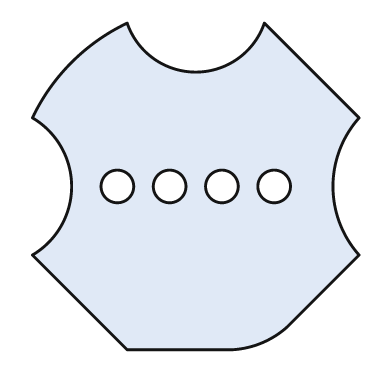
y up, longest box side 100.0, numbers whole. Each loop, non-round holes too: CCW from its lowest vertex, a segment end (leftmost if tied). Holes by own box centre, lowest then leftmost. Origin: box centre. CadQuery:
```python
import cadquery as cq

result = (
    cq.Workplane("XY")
    .moveTo(-21.0, -50.0)
    .lineTo(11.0, -50.0)
    .threePointArc((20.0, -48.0), (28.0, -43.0))
    .lineTo(50.0, -21.0)
    .threePointArc((42.0, 0.0), (50.0, 21.0))
    .lineTo(21.0, 50.0)
    .threePointArc((0.0, 35.0), (-21.0, 50.0))
    .threePointArc((-38.0, 38.0), (-50.0, 21.0))
    .threePointArc((-38.0, 0.0), (-50.0, -21.0))
    .close()
    .moveTo(-24.0, 0.0)
    .circle(5.0)
    .moveTo(-8.0, 0.0)
    .circle(5.0)
    .moveTo(8.0, 0.0)
    .circle(5.0)
    .moveTo(24.0, 0.0)
    .circle(5.0)
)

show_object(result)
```